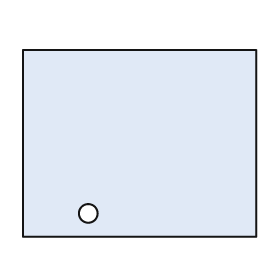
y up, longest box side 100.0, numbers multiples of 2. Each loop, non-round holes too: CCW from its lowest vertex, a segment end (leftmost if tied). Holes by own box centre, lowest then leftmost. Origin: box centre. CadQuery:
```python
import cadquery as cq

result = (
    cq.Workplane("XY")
    .moveTo(-50.0, -40.0)
    .lineTo(50.0, -40.0)
    .lineTo(50.0, 40.0)
    .lineTo(-50.0, 40.0)
    .close()
    .moveTo(-22.0, -30.0)
    .circle(4.0)
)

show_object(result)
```